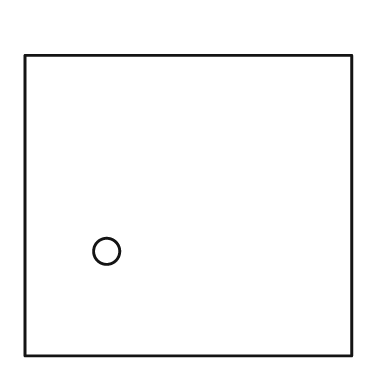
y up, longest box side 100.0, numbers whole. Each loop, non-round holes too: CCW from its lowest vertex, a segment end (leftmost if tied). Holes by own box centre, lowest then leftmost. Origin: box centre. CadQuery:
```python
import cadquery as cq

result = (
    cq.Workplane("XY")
    .moveTo(-50.0, -46.0)
    .lineTo(50.0, -46.0)
    .lineTo(50.0, 46.0)
    .lineTo(-50.0, 46.0)
    .close()
    .moveTo(-25.0, -14.0)
    .circle(4.0)
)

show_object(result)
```